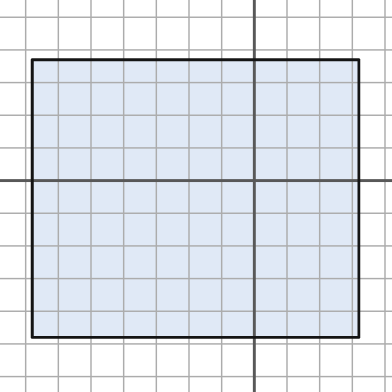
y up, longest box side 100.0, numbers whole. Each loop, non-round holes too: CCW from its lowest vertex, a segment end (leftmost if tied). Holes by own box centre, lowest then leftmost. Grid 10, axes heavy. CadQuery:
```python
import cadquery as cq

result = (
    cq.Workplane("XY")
    .moveTo(-68.0, -48.0)
    .lineTo(32.0, -48.0)
    .lineTo(32.0, 37.0)
    .lineTo(-68.0, 37.0)
    .close()
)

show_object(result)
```